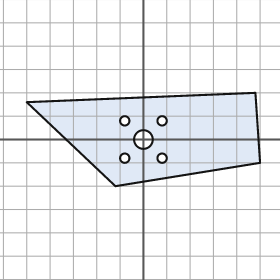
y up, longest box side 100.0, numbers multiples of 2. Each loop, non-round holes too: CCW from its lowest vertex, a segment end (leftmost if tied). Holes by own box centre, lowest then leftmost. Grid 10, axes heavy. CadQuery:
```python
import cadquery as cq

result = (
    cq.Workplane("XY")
    .moveTo(-12.0, -20.0)
    .lineTo(50.0, -10.0)
    .lineTo(48.0, 20.0)
    .lineTo(-50.0, 16.0)
    .close()
    .moveTo(-8.0, -8.0)
    .circle(2.0)
    .moveTo(8.0, -8.0)
    .circle(2.0)
    .moveTo(0.0, 0.0)
    .circle(4.0)
    .moveTo(-8.0, 8.0)
    .circle(2.0)
    .moveTo(8.0, 8.0)
    .circle(2.0)
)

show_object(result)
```